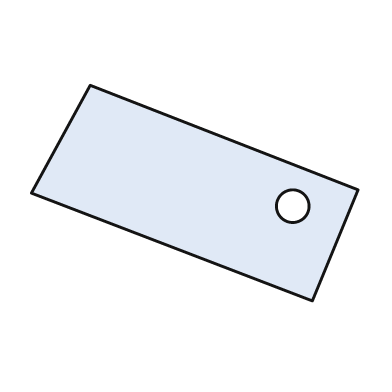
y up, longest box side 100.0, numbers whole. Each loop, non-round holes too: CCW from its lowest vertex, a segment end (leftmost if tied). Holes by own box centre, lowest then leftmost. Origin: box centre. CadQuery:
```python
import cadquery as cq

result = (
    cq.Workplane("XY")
    .moveTo(36.0, -33.0)
    .lineTo(50.0, 1.0)
    .lineTo(-32.0, 33.0)
    .lineTo(-50.0, 0.0)
    .close()
    .moveTo(30.0, -4.0)
    .circle(5.0)
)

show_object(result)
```